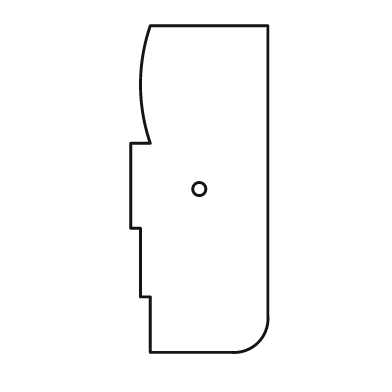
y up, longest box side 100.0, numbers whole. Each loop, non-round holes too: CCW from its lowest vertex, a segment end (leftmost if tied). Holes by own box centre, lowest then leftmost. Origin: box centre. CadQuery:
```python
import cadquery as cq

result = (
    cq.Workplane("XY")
    .moveTo(-15.0, -50.0)
    .lineTo(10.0, -50.0)
    .threePointArc((18.0, -47.0), (21.0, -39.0))
    .lineTo(21.0, 50.0)
    .lineTo(-15.0, 50.0)
    .threePointArc((-18.0, 32.0), (-15.0, 14.0))
    .lineTo(-21.0, 14.0)
    .lineTo(-21.0, -12.0)
    .lineTo(-18.0, -12.0)
    .lineTo(-18.0, -33.0)
    .lineTo(-15.0, -33.0)
    .close()
    .moveTo(0.0, 0.0)
    .circle(2.0)
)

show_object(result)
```